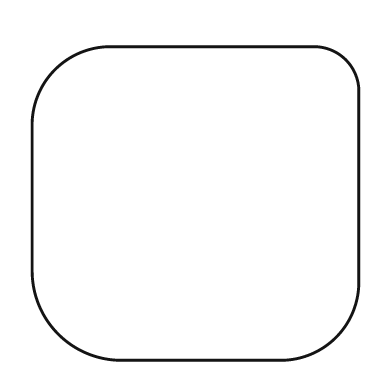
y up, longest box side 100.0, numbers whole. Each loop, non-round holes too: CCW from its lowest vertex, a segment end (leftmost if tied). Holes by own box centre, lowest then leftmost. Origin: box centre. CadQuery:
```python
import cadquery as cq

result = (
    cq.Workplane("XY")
    .moveTo(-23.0, -48.0)
    .lineTo(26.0, -48.0)
    .threePointArc((43.0, -41.0), (50.0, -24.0))
    .lineTo(50.0, 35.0)
    .threePointArc((46.0, 44.0), (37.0, 48.0))
    .lineTo(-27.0, 48.0)
    .threePointArc((-43.0, 41.0), (-50.0, 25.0))
    .lineTo(-50.0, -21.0)
    .threePointArc((-42.0, -40.0), (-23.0, -48.0))
    .close()
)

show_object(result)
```